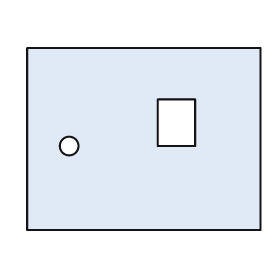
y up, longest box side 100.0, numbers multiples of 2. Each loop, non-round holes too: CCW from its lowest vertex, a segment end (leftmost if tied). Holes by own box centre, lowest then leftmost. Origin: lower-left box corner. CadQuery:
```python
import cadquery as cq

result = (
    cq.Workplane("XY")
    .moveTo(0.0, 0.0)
    .lineTo(100.0, 0.0)
    .lineTo(100.0, 78.0)
    .lineTo(0.0, 78.0)
    .close()
    .moveTo(18.0, 36.0)
    .circle(4.0)
    .moveTo(56.0, 36.0)
    .lineTo(72.0, 36.0)
    .lineTo(72.0, 56.0)
    .lineTo(56.0, 56.0)
    .close()
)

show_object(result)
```